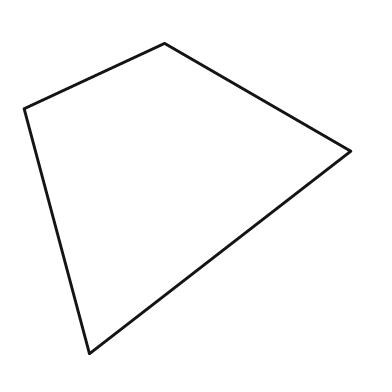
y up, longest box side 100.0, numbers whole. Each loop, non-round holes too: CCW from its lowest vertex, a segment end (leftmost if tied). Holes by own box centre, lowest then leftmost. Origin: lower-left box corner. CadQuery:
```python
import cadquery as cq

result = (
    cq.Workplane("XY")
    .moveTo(20.0, 0.0)
    .lineTo(100.0, 62.0)
    .lineTo(43.0, 95.0)
    .lineTo(0.0, 75.0)
    .close()
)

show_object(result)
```